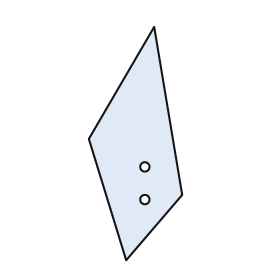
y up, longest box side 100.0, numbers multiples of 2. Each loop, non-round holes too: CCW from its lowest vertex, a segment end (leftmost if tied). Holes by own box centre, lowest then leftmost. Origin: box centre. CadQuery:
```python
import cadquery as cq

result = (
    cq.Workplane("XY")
    .moveTo(-4.0, -50.0)
    .lineTo(20.0, -22.0)
    .lineTo(8.0, 50.0)
    .lineTo(-20.0, 2.0)
    .close()
    .moveTo(4.0, -24.0)
    .circle(2.0)
    .moveTo(4.0, -10.0)
    .circle(2.0)
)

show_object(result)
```